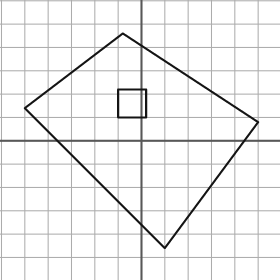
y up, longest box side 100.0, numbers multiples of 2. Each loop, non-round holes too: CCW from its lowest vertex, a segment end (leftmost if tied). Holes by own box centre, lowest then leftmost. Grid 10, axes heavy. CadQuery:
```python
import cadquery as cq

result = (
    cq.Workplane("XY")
    .moveTo(10.0, -46.0)
    .lineTo(50.0, 8.0)
    .lineTo(-8.0, 46.0)
    .lineTo(-50.0, 14.0)
    .close()
    .moveTo(-10.0, 10.0)
    .lineTo(2.0, 10.0)
    .lineTo(2.0, 22.0)
    .lineTo(-10.0, 22.0)
    .close()
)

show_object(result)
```